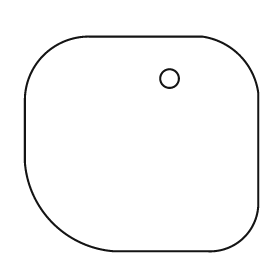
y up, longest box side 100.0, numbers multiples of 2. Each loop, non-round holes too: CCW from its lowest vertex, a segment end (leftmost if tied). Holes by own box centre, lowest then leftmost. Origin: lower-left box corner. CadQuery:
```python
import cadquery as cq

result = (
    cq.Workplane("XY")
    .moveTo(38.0, 0.0)
    .lineTo(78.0, 0.0)
    .threePointArc((94.0, 6.0), (100.0, 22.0))
    .lineTo(100.0, 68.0)
    .threePointArc((92.0, 84.0), (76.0, 92.0))
    .lineTo(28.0, 92.0)
    .threePointArc((8.0, 84.0), (0.0, 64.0))
    .lineTo(0.0, 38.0)
    .threePointArc((12.0, 12.0), (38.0, 0.0))
    .close()
    .moveTo(62.0, 74.0)
    .circle(4.0)
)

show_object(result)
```